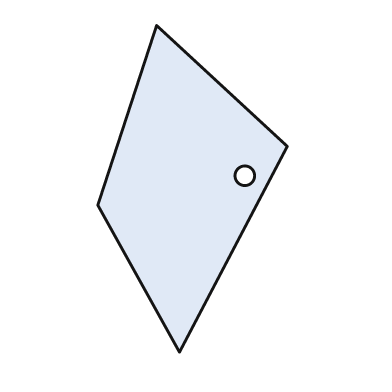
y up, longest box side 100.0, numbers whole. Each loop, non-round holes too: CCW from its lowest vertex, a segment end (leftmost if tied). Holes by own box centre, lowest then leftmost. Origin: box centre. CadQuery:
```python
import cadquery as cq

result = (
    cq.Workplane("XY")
    .moveTo(-4.0, -50.0)
    .lineTo(29.0, 13.0)
    .lineTo(-11.0, 50.0)
    .lineTo(-29.0, -5.0)
    .close()
    .moveTo(16.0, 4.0)
    .circle(3.0)
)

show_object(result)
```